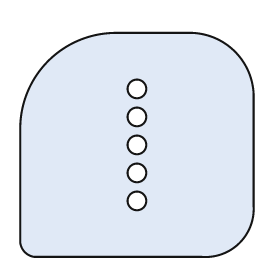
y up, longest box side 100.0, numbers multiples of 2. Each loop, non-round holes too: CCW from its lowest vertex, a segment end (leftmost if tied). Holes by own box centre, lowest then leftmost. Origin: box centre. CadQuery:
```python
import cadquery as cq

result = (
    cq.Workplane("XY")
    .moveTo(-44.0, -48.0)
    .lineTo(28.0, -48.0)
    .threePointArc((44.0, -42.0), (50.0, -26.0))
    .lineTo(50.0, 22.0)
    .threePointArc((42.0, 40.0), (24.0, 48.0))
    .lineTo(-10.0, 48.0)
    .threePointArc((-38.0, 36.0), (-50.0, 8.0))
    .lineTo(-50.0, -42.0)
    .threePointArc((-48.0, -46.0), (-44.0, -48.0))
    .close()
    .moveTo(0.0, -24.0)
    .circle(4.0)
    .moveTo(0.0, -12.0)
    .circle(4.0)
    .moveTo(0.0, 0.0)
    .circle(4.0)
    .moveTo(0.0, 12.0)
    .circle(4.0)
    .moveTo(0.0, 24.0)
    .circle(4.0)
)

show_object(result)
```